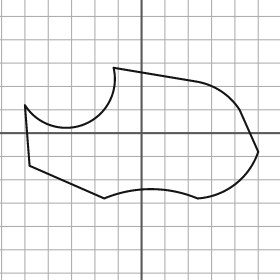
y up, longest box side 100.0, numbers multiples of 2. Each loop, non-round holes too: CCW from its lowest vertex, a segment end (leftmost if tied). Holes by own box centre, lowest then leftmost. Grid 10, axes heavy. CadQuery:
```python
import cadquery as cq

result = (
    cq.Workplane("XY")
    .moveTo(-16.0, -28.0)
    .threePointArc((4.0, -24.0), (24.0, -28.0))
    .threePointArc((40.0, -22.0), (50.0, -8.0))
    .lineTo(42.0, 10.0)
    .threePointArc((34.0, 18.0), (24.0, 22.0))
    .lineTo(-12.0, 28.0)
    .threePointArc((-24.0, 4.0), (-50.0, 12.0))
    .lineTo(-48.0, -14.0)
    .close()
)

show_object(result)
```